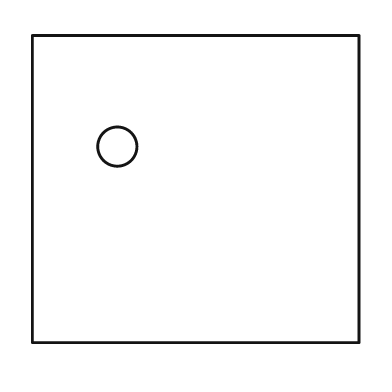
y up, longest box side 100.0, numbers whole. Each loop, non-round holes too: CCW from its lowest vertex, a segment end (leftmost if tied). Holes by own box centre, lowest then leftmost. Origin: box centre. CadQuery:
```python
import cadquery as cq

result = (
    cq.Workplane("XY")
    .moveTo(-50.0, -47.0)
    .lineTo(50.0, -47.0)
    .lineTo(50.0, 47.0)
    .lineTo(-50.0, 47.0)
    .close()
    .moveTo(-24.0, 13.0)
    .circle(6.0)
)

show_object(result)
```